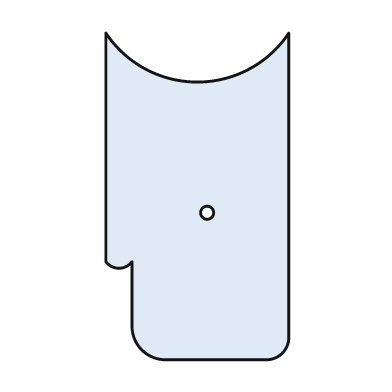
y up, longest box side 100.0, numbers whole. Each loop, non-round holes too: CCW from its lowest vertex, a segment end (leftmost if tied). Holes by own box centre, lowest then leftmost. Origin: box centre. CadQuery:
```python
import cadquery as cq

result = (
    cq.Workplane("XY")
    .moveTo(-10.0, -50.0)
    .lineTo(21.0, -50.0)
    .threePointArc((26.0, -48.0), (28.0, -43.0))
    .lineTo(28.0, 50.0)
    .threePointArc((0.0, 35.0), (-28.0, 50.0))
    .lineTo(-28.0, -20.0)
    .threePointArc((-24.0, -22.0), (-20.0, -20.0))
    .lineTo(-20.0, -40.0)
    .threePointArc((-17.0, -47.0), (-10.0, -50.0))
    .close()
    .moveTo(3.0, -5.0)
    .circle(2.0)
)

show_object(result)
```